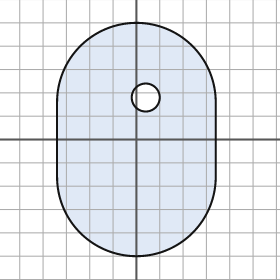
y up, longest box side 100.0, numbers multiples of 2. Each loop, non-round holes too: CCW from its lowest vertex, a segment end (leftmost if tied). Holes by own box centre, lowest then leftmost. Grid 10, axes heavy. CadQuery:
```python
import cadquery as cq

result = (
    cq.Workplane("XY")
    .moveTo(-34.0, -16.0)
    .threePointArc((0.0, -50.0), (34.0, -16.0))
    .lineTo(34.0, 16.0)
    .threePointArc((0.0, 50.0), (-34.0, 16.0))
    .close()
    .moveTo(4.0, 18.0)
    .circle(6.0)
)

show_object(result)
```